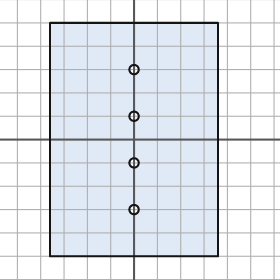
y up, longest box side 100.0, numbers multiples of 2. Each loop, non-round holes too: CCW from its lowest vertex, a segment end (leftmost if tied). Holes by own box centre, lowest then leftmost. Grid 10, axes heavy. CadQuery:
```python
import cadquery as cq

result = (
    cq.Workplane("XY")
    .moveTo(-36.0, -50.0)
    .lineTo(36.0, -50.0)
    .lineTo(36.0, 50.0)
    .lineTo(-36.0, 50.0)
    .close()
    .moveTo(0.0, -30.0)
    .circle(2.0)
    .moveTo(0.0, -10.0)
    .circle(2.0)
    .moveTo(0.0, 10.0)
    .circle(2.0)
    .moveTo(0.0, 30.0)
    .circle(2.0)
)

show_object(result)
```